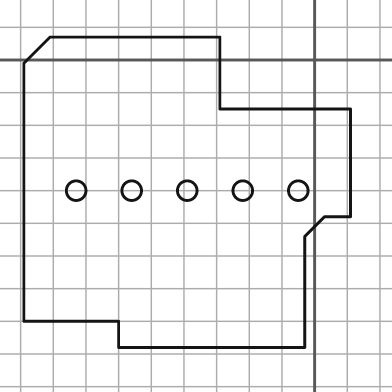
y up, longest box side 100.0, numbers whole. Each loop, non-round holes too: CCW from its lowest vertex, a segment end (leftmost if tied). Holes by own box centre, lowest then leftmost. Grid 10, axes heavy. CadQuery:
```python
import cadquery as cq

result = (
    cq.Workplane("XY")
    .moveTo(-60.0, -88.0)
    .lineTo(-3.0, -88.0)
    .lineTo(-3.0, -54.0)
    .lineTo(3.0, -48.0)
    .lineTo(11.0, -48.0)
    .lineTo(11.0, -15.0)
    .lineTo(-29.0, -15.0)
    .lineTo(-29.0, 7.0)
    .lineTo(-81.0, 7.0)
    .lineTo(-89.0, -1.0)
    .lineTo(-89.0, -80.0)
    .lineTo(-60.0, -80.0)
    .close()
    .moveTo(-73.0, -40.0)
    .circle(3.0)
    .moveTo(-56.0, -40.0)
    .circle(3.0)
    .moveTo(-39.0, -40.0)
    .circle(3.0)
    .moveTo(-22.0, -40.0)
    .circle(3.0)
    .moveTo(-5.0, -40.0)
    .circle(3.0)
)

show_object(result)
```